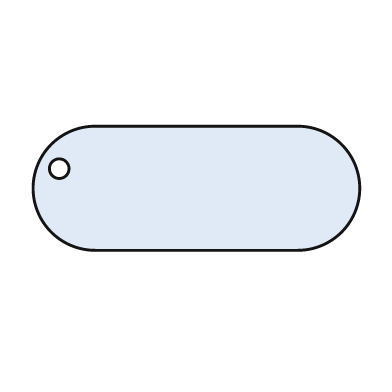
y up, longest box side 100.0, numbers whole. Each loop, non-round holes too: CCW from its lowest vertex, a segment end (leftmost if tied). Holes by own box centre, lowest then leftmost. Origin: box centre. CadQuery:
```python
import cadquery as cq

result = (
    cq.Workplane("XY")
    .moveTo(-31.0, -19.0)
    .lineTo(31.0, -19.0)
    .threePointArc((50.0, 0.0), (31.0, 19.0))
    .lineTo(-31.0, 19.0)
    .threePointArc((-50.0, 0.0), (-31.0, -19.0))
    .close()
    .moveTo(-42.0, 6.0)
    .circle(3.0)
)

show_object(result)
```